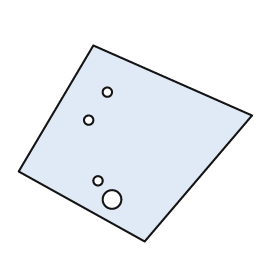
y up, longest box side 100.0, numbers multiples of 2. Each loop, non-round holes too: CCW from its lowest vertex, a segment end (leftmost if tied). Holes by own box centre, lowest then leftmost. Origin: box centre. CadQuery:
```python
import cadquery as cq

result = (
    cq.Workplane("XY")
    .moveTo(4.0, -42.0)
    .lineTo(50.0, 12.0)
    .lineTo(-18.0, 42.0)
    .lineTo(-50.0, -12.0)
    .close()
    .moveTo(-10.0, -24.0)
    .circle(4.0)
    .moveTo(-16.0, -16.0)
    .circle(2.0)
    .moveTo(-20.0, 10.0)
    .circle(2.0)
    .moveTo(-12.0, 22.0)
    .circle(2.0)
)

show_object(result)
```